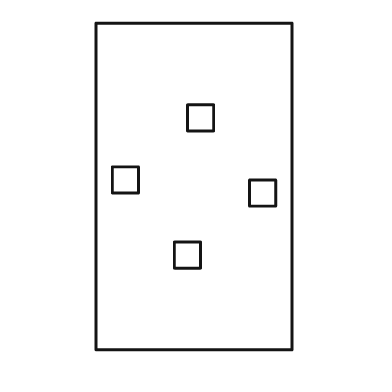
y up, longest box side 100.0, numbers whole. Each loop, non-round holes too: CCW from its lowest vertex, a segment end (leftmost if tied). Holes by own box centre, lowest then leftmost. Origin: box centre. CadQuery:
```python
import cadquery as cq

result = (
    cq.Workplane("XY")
    .moveTo(-30.0, -50.0)
    .lineTo(30.0, -50.0)
    .lineTo(30.0, 50.0)
    .lineTo(-30.0, 50.0)
    .close()
    .moveTo(-6.0, -25.0)
    .lineTo(2.0, -25.0)
    .lineTo(2.0, -17.0)
    .lineTo(-6.0, -17.0)
    .close()
    .moveTo(17.0, -6.0)
    .lineTo(25.0, -6.0)
    .lineTo(25.0, 2.0)
    .lineTo(17.0, 2.0)
    .close()
    .moveTo(-25.0, -2.0)
    .lineTo(-17.0, -2.0)
    .lineTo(-17.0, 6.0)
    .lineTo(-25.0, 6.0)
    .close()
    .moveTo(-2.0, 17.0)
    .lineTo(6.0, 17.0)
    .lineTo(6.0, 25.0)
    .lineTo(-2.0, 25.0)
    .close()
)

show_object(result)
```